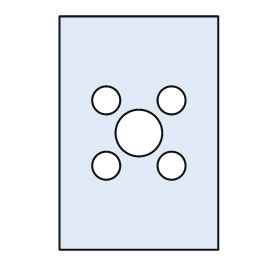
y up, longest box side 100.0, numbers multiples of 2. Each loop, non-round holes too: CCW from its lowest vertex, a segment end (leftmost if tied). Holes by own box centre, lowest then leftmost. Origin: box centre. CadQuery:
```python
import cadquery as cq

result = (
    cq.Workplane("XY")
    .moveTo(-34.0, -50.0)
    .lineTo(34.0, -50.0)
    .lineTo(34.0, 50.0)
    .lineTo(-34.0, 50.0)
    .close()
    .moveTo(-14.0, -14.0)
    .circle(6.0)
    .moveTo(14.0, -14.0)
    .circle(6.0)
    .moveTo(0.0, 0.0)
    .circle(10.0)
    .moveTo(-14.0, 14.0)
    .circle(6.0)
    .moveTo(14.0, 14.0)
    .circle(6.0)
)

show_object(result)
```